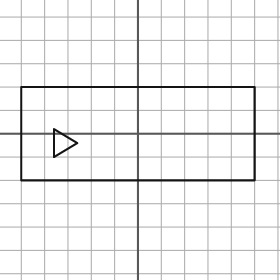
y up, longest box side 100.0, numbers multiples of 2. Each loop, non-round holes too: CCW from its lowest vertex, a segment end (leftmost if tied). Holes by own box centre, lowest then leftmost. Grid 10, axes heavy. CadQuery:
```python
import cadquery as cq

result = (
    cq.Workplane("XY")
    .moveTo(-50.0, -20.0)
    .lineTo(50.0, -20.0)
    .lineTo(50.0, 20.0)
    .lineTo(-50.0, 20.0)
    .close()
    .moveTo(-36.0, -10.0)
    .lineTo(-26.0, -4.0)
    .lineTo(-36.0, 2.0)
    .close()
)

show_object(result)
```